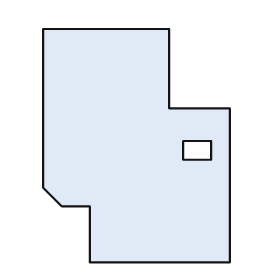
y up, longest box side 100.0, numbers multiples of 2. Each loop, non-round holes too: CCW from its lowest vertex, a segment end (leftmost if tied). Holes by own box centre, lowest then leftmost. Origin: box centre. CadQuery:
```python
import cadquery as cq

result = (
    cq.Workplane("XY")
    .moveTo(-20.0, -50.0)
    .lineTo(40.0, -50.0)
    .lineTo(40.0, 16.0)
    .lineTo(14.0, 16.0)
    .lineTo(14.0, 50.0)
    .lineTo(-40.0, 50.0)
    .lineTo(-40.0, -18.0)
    .lineTo(-32.0, -26.0)
    .lineTo(-20.0, -26.0)
    .close()
    .moveTo(20.0, -6.0)
    .lineTo(32.0, -6.0)
    .lineTo(32.0, 2.0)
    .lineTo(20.0, 2.0)
    .close()
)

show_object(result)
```